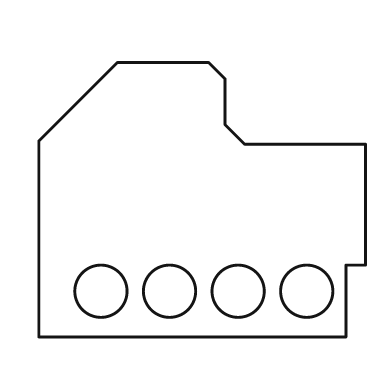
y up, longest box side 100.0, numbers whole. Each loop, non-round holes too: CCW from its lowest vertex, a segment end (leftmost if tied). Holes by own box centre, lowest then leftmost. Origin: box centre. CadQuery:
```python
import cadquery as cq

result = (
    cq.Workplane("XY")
    .moveTo(-50.0, -42.0)
    .lineTo(44.0, -42.0)
    .lineTo(44.0, -20.0)
    .lineTo(50.0, -20.0)
    .lineTo(50.0, 17.0)
    .lineTo(13.0, 17.0)
    .lineTo(7.0, 23.0)
    .lineTo(7.0, 37.0)
    .lineTo(2.0, 42.0)
    .lineTo(-26.0, 42.0)
    .lineTo(-50.0, 18.0)
    .close()
    .moveTo(-31.0, -28.0)
    .circle(8.0)
    .moveTo(-10.0, -28.0)
    .circle(8.0)
    .moveTo(11.0, -28.0)
    .circle(8.0)
    .moveTo(32.0, -28.0)
    .circle(8.0)
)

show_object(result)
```